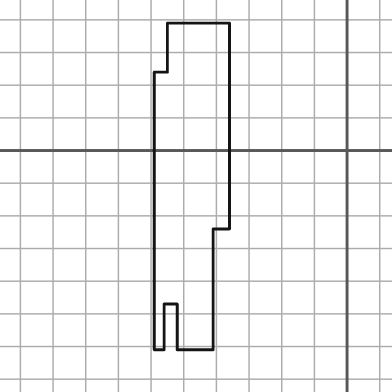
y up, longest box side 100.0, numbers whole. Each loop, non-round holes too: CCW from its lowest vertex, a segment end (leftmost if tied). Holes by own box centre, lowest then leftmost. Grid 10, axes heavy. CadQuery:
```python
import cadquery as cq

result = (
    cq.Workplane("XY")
    .moveTo(-59.0, -61.0)
    .lineTo(-56.0, -61.0)
    .lineTo(-56.0, -47.0)
    .lineTo(-52.0, -47.0)
    .lineTo(-52.0, -61.0)
    .lineTo(-41.0, -61.0)
    .lineTo(-41.0, -24.0)
    .lineTo(-36.0, -24.0)
    .lineTo(-36.0, 39.0)
    .lineTo(-55.0, 39.0)
    .lineTo(-55.0, 24.0)
    .lineTo(-59.0, 24.0)
    .close()
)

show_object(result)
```